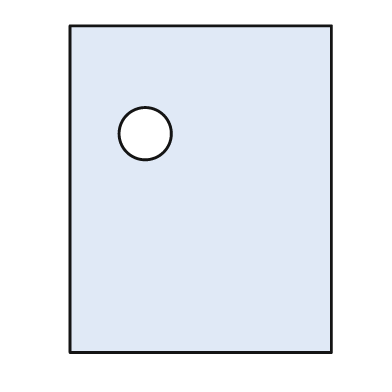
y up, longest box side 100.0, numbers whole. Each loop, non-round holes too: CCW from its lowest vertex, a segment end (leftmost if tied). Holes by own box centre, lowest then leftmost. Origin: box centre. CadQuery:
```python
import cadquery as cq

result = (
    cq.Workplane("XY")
    .moveTo(-40.0, -50.0)
    .lineTo(40.0, -50.0)
    .lineTo(40.0, 50.0)
    .lineTo(-40.0, 50.0)
    .close()
    .moveTo(-17.0, 17.0)
    .circle(8.0)
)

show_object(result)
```